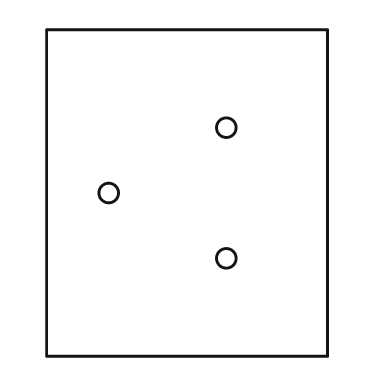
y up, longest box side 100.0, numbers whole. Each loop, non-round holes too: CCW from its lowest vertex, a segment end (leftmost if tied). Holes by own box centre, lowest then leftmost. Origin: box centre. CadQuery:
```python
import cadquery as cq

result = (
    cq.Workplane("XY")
    .moveTo(-43.0, -50.0)
    .lineTo(43.0, -50.0)
    .lineTo(43.0, 50.0)
    .lineTo(-43.0, 50.0)
    .close()
    .moveTo(12.0, -20.0)
    .circle(3.0)
    .moveTo(-24.0, 0.0)
    .circle(3.0)
    .moveTo(12.0, 20.0)
    .circle(3.0)
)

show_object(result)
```